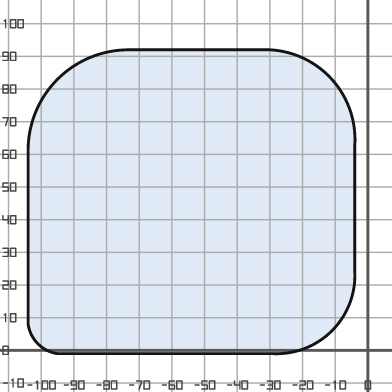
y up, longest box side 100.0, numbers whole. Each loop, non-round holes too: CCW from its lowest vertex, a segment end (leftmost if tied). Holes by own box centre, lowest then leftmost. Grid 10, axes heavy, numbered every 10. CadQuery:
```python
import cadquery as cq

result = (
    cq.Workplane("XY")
    .moveTo(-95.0, -1.0)
    .lineTo(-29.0, -1.0)
    .threePointArc((-11.0, 6.0), (-4.0, 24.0))
    .lineTo(-4.0, 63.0)
    .threePointArc((-12.0, 84.0), (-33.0, 92.0))
    .lineTo(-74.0, 92.0)
    .threePointArc((-95.0, 83.0), (-104.0, 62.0))
    .lineTo(-104.0, 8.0)
    .threePointArc((-101.0, 2.0), (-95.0, -1.0))
    .close()
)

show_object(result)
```